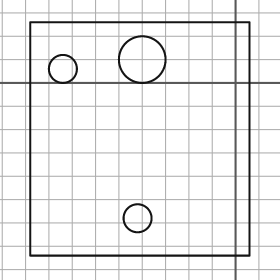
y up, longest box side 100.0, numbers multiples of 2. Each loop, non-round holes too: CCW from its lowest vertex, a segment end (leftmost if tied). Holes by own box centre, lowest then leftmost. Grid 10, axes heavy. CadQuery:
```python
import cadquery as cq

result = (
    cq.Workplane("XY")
    .moveTo(-88.0, -74.0)
    .lineTo(6.0, -74.0)
    .lineTo(6.0, 26.0)
    .lineTo(-88.0, 26.0)
    .close()
    .moveTo(-42.0, -58.0)
    .circle(6.0)
    .moveTo(-74.0, 6.0)
    .circle(6.0)
    .moveTo(-40.0, 10.0)
    .circle(10.0)
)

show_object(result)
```